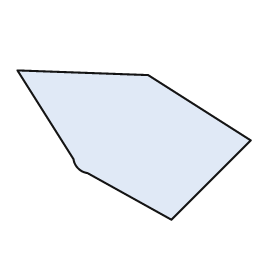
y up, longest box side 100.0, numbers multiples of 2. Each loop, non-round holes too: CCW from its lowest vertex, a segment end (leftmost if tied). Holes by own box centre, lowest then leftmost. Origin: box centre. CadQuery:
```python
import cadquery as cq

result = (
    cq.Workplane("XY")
    .moveTo(16.0, -32.0)
    .lineTo(50.0, 2.0)
    .lineTo(6.0, 30.0)
    .lineTo(-50.0, 32.0)
    .lineTo(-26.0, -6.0)
    .threePointArc((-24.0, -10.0), (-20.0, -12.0))
    .close()
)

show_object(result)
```